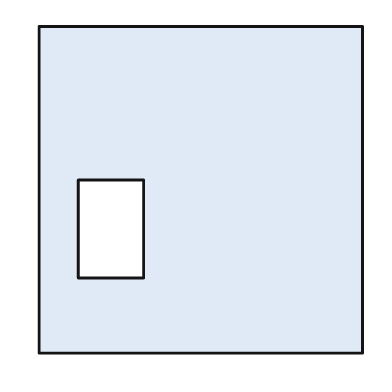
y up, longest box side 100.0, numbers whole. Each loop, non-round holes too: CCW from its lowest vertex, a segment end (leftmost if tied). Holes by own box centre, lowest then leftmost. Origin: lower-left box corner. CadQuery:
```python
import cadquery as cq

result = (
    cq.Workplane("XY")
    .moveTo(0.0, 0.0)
    .lineTo(99.0, 0.0)
    .lineTo(99.0, 100.0)
    .lineTo(0.0, 100.0)
    .close()
    .moveTo(12.0, 23.0)
    .lineTo(32.0, 23.0)
    .lineTo(32.0, 53.0)
    .lineTo(12.0, 53.0)
    .close()
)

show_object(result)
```